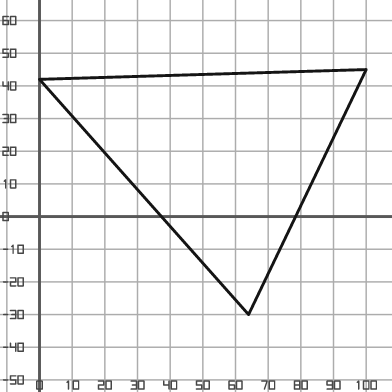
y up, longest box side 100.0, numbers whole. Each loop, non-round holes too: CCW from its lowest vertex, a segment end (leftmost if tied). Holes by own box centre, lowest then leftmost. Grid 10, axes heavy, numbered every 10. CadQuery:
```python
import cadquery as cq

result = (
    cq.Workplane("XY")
    .moveTo(64.0, -30.0)
    .lineTo(100.0, 45.0)
    .lineTo(0.0, 42.0)
    .close()
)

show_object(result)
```